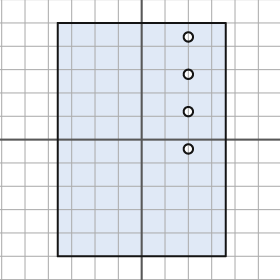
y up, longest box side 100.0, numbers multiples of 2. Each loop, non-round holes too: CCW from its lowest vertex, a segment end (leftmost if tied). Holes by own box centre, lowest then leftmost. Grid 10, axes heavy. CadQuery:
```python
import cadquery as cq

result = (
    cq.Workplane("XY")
    .moveTo(-36.0, -50.0)
    .lineTo(36.0, -50.0)
    .lineTo(36.0, 50.0)
    .lineTo(-36.0, 50.0)
    .close()
    .moveTo(20.0, -4.0)
    .circle(2.0)
    .moveTo(20.0, 12.0)
    .circle(2.0)
    .moveTo(20.0, 28.0)
    .circle(2.0)
    .moveTo(20.0, 44.0)
    .circle(2.0)
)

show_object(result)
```